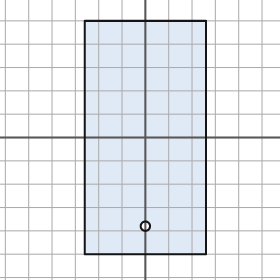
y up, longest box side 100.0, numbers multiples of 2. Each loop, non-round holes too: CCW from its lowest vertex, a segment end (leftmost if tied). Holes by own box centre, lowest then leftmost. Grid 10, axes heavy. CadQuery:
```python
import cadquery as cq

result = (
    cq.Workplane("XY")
    .moveTo(-26.0, -50.0)
    .lineTo(26.0, -50.0)
    .lineTo(26.0, 50.0)
    .lineTo(-26.0, 50.0)
    .close()
    .moveTo(0.0, -38.0)
    .circle(2.0)
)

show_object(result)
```